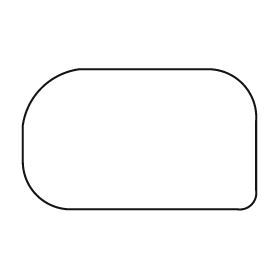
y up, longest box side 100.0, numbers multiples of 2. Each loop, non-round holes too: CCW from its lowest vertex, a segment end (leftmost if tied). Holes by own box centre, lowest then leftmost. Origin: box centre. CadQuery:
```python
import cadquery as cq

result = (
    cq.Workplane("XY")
    .moveTo(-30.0, -30.0)
    .lineTo(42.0, -30.0)
    .threePointArc((48.0, -28.0), (50.0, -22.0))
    .lineTo(50.0, 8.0)
    .threePointArc((44.0, 24.0), (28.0, 30.0))
    .lineTo(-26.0, 30.0)
    .threePointArc((-42.0, 22.0), (-50.0, 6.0))
    .lineTo(-50.0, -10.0)
    .threePointArc((-44.0, -24.0), (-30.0, -30.0))
    .close()
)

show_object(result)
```